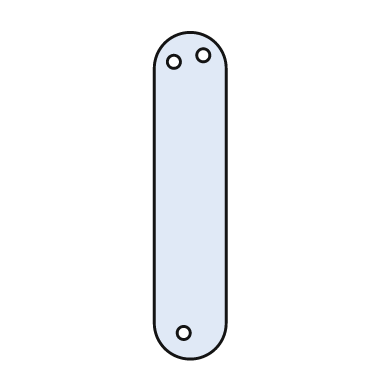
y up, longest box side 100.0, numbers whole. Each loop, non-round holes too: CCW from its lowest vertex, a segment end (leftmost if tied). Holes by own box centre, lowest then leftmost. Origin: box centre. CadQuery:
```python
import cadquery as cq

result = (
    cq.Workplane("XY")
    .moveTo(-11.0, -39.0)
    .threePointArc((0.0, -50.0), (11.0, -39.0))
    .lineTo(11.0, 39.0)
    .threePointArc((0.0, 50.0), (-11.0, 39.0))
    .close()
    .moveTo(-2.0, -42.0)
    .circle(2.0)
    .moveTo(-5.0, 41.0)
    .circle(2.0)
    .moveTo(4.0, 43.0)
    .circle(2.0)
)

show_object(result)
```